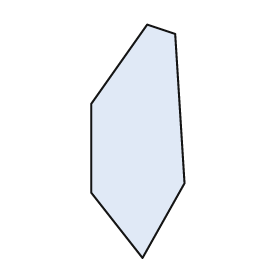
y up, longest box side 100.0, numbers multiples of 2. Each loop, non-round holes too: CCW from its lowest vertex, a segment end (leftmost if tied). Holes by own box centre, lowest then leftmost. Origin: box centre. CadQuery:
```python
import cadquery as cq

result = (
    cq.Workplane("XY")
    .moveTo(2.0, -50.0)
    .lineTo(20.0, -18.0)
    .lineTo(16.0, 46.0)
    .lineTo(4.0, 50.0)
    .lineTo(-20.0, 16.0)
    .lineTo(-20.0, -22.0)
    .close()
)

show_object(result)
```